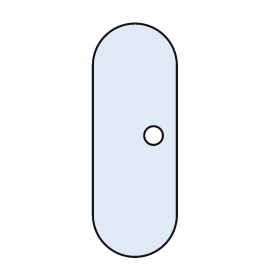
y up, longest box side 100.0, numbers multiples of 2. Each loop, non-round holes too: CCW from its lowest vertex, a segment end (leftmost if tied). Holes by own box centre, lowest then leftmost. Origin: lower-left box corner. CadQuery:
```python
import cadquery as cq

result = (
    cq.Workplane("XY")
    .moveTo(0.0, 18.0)
    .threePointArc((18.0, 0.0), (36.0, 18.0))
    .lineTo(36.0, 82.0)
    .threePointArc((18.0, 100.0), (0.0, 82.0))
    .close()
    .moveTo(26.0, 52.0)
    .circle(4.0)
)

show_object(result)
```